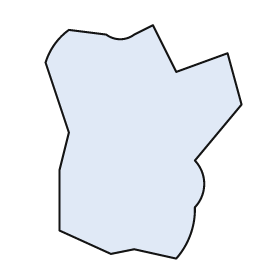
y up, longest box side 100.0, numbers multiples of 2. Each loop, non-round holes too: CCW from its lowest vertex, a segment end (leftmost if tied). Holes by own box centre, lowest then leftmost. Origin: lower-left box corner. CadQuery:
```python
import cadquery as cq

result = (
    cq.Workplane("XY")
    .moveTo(56.0, 0.0)
    .threePointArc((62.0, 10.0), (64.0, 22.0))
    .threePointArc((68.0, 32.0), (64.0, 42.0))
    .lineTo(84.0, 66.0)
    .lineTo(78.0, 88.0)
    .lineTo(56.0, 80.0)
    .lineTo(46.0, 100.0)
    .lineTo(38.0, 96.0)
    .threePointArc((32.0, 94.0), (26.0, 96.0))
    .lineTo(10.0, 98.0)
    .threePointArc((4.0, 92.0), (0.0, 84.0))
    .lineTo(10.0, 54.0)
    .lineTo(6.0, 38.0)
    .lineTo(6.0, 12.0)
    .lineTo(28.0, 2.0)
    .lineTo(38.0, 4.0)
    .close()
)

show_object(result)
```